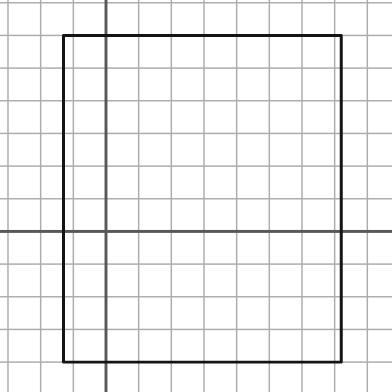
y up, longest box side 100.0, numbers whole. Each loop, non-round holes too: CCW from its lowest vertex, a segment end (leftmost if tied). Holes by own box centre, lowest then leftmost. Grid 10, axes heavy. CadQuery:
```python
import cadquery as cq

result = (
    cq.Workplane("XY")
    .moveTo(-13.0, -40.0)
    .lineTo(72.0, -40.0)
    .lineTo(72.0, 60.0)
    .lineTo(-13.0, 60.0)
    .close()
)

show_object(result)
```